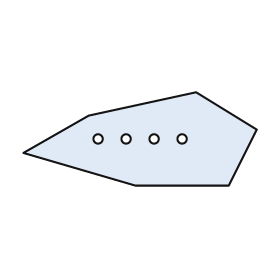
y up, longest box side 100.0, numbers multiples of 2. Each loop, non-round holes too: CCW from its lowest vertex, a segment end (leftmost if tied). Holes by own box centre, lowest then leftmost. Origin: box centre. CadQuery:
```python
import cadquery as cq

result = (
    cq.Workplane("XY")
    .moveTo(-2.0, -20.0)
    .lineTo(38.0, -20.0)
    .lineTo(50.0, 4.0)
    .lineTo(24.0, 20.0)
    .lineTo(-22.0, 10.0)
    .lineTo(-50.0, -6.0)
    .close()
    .moveTo(-18.0, 0.0)
    .circle(2.0)
    .moveTo(-6.0, 0.0)
    .circle(2.0)
    .moveTo(6.0, 0.0)
    .circle(2.0)
    .moveTo(18.0, 0.0)
    .circle(2.0)
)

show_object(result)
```